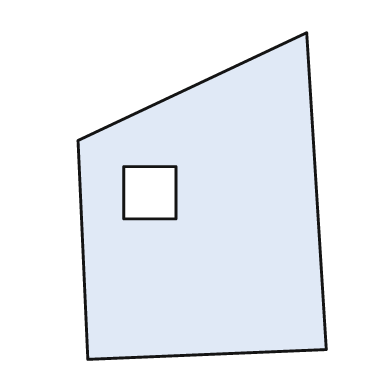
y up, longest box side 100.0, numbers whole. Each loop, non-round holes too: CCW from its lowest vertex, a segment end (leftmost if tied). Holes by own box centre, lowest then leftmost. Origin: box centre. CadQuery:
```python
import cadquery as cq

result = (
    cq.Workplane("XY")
    .moveTo(-35.0, -50.0)
    .lineTo(38.0, -47.0)
    .lineTo(32.0, 50.0)
    .lineTo(-38.0, 17.0)
    .close()
    .moveTo(-24.0, -7.0)
    .lineTo(-8.0, -7.0)
    .lineTo(-8.0, 9.0)
    .lineTo(-24.0, 9.0)
    .close()
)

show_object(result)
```